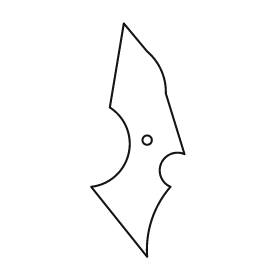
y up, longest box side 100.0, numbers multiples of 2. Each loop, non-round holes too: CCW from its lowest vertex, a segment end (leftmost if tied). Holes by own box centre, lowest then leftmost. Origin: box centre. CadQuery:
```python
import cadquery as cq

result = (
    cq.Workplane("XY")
    .moveTo(4.0, -50.0)
    .threePointArc((6.0, -34.0), (14.0, -20.0))
    .threePointArc((10.0, -10.0), (20.0, -6.0))
    .lineTo(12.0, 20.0)
    .threePointArc((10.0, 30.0), (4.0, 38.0))
    .lineTo(-6.0, 50.0)
    .lineTo(-12.0, 14.0)
    .threePointArc((-4.0, -6.0), (-20.0, -20.0))
    .close()
    .moveTo(4.0, 0.0)
    .circle(2.0)
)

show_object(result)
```